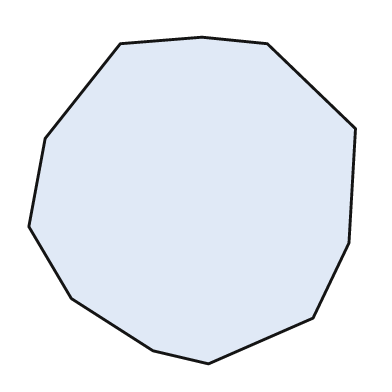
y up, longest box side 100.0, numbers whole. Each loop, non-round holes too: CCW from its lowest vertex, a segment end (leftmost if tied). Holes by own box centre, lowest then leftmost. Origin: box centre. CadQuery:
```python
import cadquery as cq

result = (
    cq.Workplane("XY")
    .moveTo(5.0, -50.0)
    .lineTo(37.0, -36.0)
    .lineTo(48.0, -13.0)
    .lineTo(50.0, 22.0)
    .lineTo(23.0, 48.0)
    .lineTo(3.0, 50.0)
    .lineTo(-22.0, 48.0)
    .lineTo(-45.0, 19.0)
    .lineTo(-50.0, -8.0)
    .lineTo(-37.0, -30.0)
    .lineTo(-12.0, -46.0)
    .close()
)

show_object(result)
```